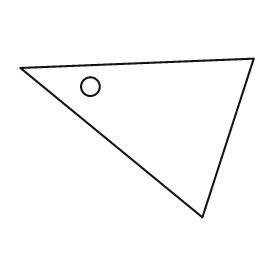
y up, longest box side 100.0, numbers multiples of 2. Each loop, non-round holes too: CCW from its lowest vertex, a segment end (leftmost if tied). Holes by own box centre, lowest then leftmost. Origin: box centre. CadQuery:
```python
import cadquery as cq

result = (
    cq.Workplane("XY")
    .moveTo(28.0, -34.0)
    .lineTo(50.0, 34.0)
    .lineTo(-50.0, 30.0)
    .close()
    .moveTo(-20.0, 22.0)
    .circle(4.0)
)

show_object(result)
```